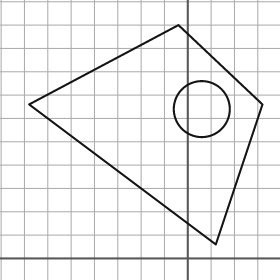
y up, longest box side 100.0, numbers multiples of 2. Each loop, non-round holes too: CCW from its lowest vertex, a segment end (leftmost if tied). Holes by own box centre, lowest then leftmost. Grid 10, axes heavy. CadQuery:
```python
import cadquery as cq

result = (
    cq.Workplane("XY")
    .moveTo(12.0, 6.0)
    .lineTo(32.0, 66.0)
    .lineTo(-4.0, 100.0)
    .lineTo(-68.0, 66.0)
    .close()
    .moveTo(6.0, 64.0)
    .circle(12.0)
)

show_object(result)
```